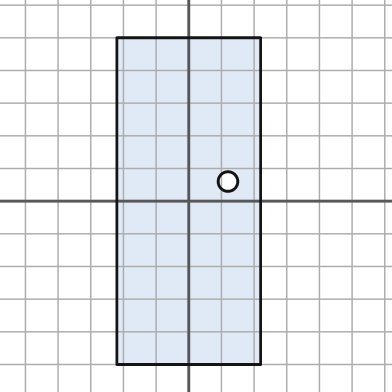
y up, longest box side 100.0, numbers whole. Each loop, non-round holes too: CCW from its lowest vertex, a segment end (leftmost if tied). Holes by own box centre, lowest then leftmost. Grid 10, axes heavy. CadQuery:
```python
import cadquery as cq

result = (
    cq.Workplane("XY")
    .moveTo(-22.0, -50.0)
    .lineTo(22.0, -50.0)
    .lineTo(22.0, 50.0)
    .lineTo(-22.0, 50.0)
    .close()
    .moveTo(12.0, 6.0)
    .circle(3.0)
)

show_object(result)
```